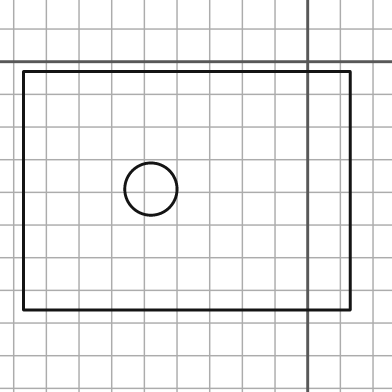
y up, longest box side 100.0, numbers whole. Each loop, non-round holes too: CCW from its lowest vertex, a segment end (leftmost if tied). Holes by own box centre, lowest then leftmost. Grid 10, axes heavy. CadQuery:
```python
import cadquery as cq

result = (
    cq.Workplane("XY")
    .moveTo(-87.0, -76.0)
    .lineTo(13.0, -76.0)
    .lineTo(13.0, -3.0)
    .lineTo(-87.0, -3.0)
    .close()
    .moveTo(-48.0, -39.0)
    .circle(8.0)
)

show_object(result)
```